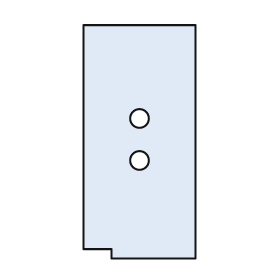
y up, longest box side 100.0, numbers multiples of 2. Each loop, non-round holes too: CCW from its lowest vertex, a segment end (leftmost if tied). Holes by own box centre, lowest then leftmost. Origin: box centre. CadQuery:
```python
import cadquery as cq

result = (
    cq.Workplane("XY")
    .moveTo(-12.0, -50.0)
    .lineTo(24.0, -50.0)
    .lineTo(24.0, 50.0)
    .lineTo(-24.0, 50.0)
    .lineTo(-24.0, -46.0)
    .lineTo(-12.0, -46.0)
    .close()
    .moveTo(0.0, -8.0)
    .circle(4.0)
    .moveTo(0.0, 10.0)
    .circle(4.0)
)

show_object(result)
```